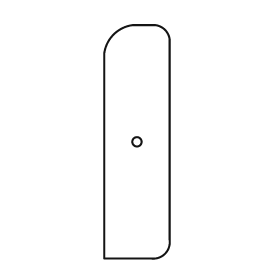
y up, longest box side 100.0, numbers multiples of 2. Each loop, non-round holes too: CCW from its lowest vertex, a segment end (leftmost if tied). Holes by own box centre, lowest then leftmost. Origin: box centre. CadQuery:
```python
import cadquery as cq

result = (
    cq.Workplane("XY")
    .moveTo(-14.0, -50.0)
    .lineTo(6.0, -50.0)
    .threePointArc((12.0, -48.0), (14.0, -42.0))
    .lineTo(14.0, 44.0)
    .threePointArc((12.0, 48.0), (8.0, 50.0))
    .lineTo(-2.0, 50.0)
    .threePointArc((-10.0, 46.0), (-14.0, 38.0))
    .close()
    .moveTo(0.0, 0.0)
    .circle(2.0)
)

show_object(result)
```